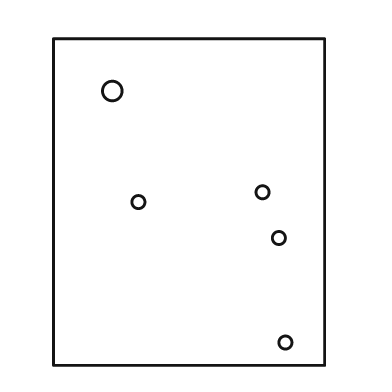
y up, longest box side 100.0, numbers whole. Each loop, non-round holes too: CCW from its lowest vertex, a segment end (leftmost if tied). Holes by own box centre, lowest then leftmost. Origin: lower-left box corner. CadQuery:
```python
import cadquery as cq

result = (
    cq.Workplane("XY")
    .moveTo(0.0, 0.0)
    .lineTo(83.0, 0.0)
    .lineTo(83.0, 100.0)
    .lineTo(0.0, 100.0)
    .close()
    .moveTo(71.0, 7.0)
    .circle(2.0)
    .moveTo(69.0, 39.0)
    .circle(2.0)
    .moveTo(26.0, 50.0)
    .circle(2.0)
    .moveTo(64.0, 53.0)
    .circle(2.0)
    .moveTo(18.0, 84.0)
    .circle(3.0)
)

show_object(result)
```